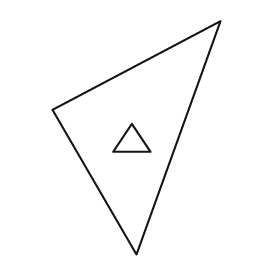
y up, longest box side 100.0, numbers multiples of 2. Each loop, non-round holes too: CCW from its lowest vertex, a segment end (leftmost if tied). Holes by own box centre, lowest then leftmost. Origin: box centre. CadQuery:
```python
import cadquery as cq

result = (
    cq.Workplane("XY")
    .moveTo(0.0, -50.0)
    .lineTo(36.0, 50.0)
    .lineTo(-36.0, 12.0)
    .close()
    .moveTo(-10.0, -6.0)
    .lineTo(6.0, -6.0)
    .lineTo(-2.0, 6.0)
    .close()
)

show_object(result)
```